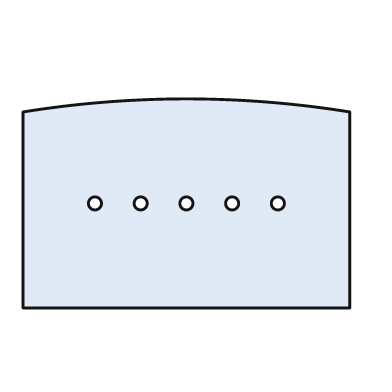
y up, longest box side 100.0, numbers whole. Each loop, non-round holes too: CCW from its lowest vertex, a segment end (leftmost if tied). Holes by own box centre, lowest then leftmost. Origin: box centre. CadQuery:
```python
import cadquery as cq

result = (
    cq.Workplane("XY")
    .moveTo(-50.0, -32.0)
    .lineTo(50.0, -32.0)
    .lineTo(50.0, 28.0)
    .threePointArc((0.0, 32.0), (-50.0, 28.0))
    .close()
    .moveTo(-28.0, 0.0)
    .circle(2.0)
    .moveTo(-14.0, 0.0)
    .circle(2.0)
    .moveTo(0.0, 0.0)
    .circle(2.0)
    .moveTo(14.0, 0.0)
    .circle(2.0)
    .moveTo(28.0, 0.0)
    .circle(2.0)
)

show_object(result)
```